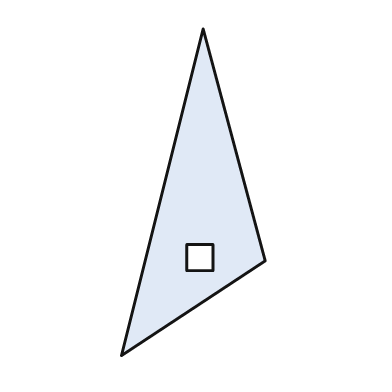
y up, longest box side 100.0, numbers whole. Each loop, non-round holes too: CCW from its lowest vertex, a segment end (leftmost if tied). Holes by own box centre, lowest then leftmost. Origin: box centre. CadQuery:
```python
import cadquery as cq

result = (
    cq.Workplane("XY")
    .moveTo(-22.0, -50.0)
    .lineTo(22.0, -21.0)
    .lineTo(3.0, 50.0)
    .close()
    .moveTo(-2.0, -24.0)
    .lineTo(6.0, -24.0)
    .lineTo(6.0, -16.0)
    .lineTo(-2.0, -16.0)
    .close()
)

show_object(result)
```